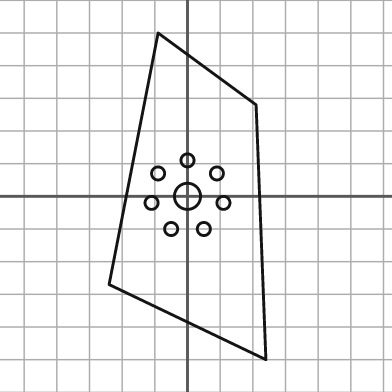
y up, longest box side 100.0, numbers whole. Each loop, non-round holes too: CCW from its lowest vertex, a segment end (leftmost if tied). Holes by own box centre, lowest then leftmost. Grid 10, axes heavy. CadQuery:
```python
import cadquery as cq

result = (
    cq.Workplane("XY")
    .moveTo(24.0, -50.0)
    .lineTo(21.0, 28.0)
    .lineTo(-9.0, 50.0)
    .lineTo(-24.0, -27.0)
    .close()
    .moveTo(-5.0, -10.0)
    .circle(2.0)
    .moveTo(5.0, -10.0)
    .circle(2.0)
    .moveTo(-11.0, -2.0)
    .circle(2.0)
    .moveTo(11.0, -2.0)
    .circle(2.0)
    .moveTo(0.0, 0.0)
    .circle(4.0)
    .moveTo(-9.0, 7.0)
    .circle(2.0)
    .moveTo(9.0, 7.0)
    .circle(2.0)
    .moveTo(0.0, 11.0)
    .circle(2.0)
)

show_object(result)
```